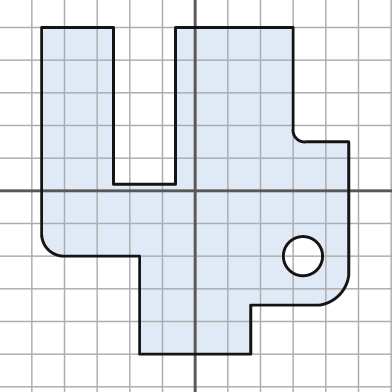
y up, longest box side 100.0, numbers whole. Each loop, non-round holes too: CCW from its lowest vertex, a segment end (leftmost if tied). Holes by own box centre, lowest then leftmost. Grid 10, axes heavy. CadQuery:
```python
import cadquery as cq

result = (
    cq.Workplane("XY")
    .moveTo(-17.0, -50.0)
    .lineTo(17.0, -50.0)
    .lineTo(17.0, -35.0)
    .lineTo(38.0, -35.0)
    .threePointArc((44.0, -32.0), (47.0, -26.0))
    .lineTo(47.0, 15.0)
    .lineTo(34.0, 15.0)
    .threePointArc((31.0, 16.0), (30.0, 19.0))
    .lineTo(30.0, 50.0)
    .lineTo(-6.0, 50.0)
    .lineTo(-6.0, 2.0)
    .lineTo(-25.0, 2.0)
    .lineTo(-25.0, 50.0)
    .lineTo(-47.0, 50.0)
    .lineTo(-47.0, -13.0)
    .threePointArc((-45.0, -18.0), (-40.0, -20.0))
    .lineTo(-17.0, -20.0)
    .close()
    .moveTo(33.0, -20.0)
    .circle(6.0)
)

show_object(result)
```